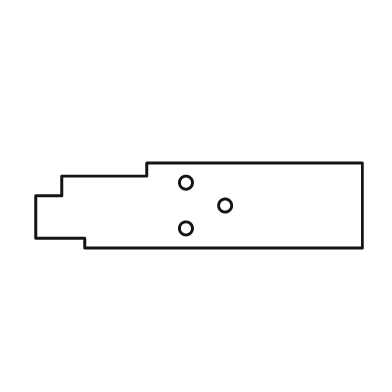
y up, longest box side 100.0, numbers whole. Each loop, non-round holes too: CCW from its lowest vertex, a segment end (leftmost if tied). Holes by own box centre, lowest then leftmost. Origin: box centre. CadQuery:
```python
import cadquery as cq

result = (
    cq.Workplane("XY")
    .moveTo(-35.0, -13.0)
    .lineTo(50.0, -13.0)
    .lineTo(50.0, 13.0)
    .lineTo(-16.0, 13.0)
    .lineTo(-16.0, 9.0)
    .lineTo(-42.0, 9.0)
    .lineTo(-42.0, 3.0)
    .lineTo(-50.0, 3.0)
    .lineTo(-50.0, -10.0)
    .lineTo(-35.0, -10.0)
    .close()
    .moveTo(-4.0, -7.0)
    .circle(2.0)
    .moveTo(8.0, 0.0)
    .circle(2.0)
    .moveTo(-4.0, 7.0)
    .circle(2.0)
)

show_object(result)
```